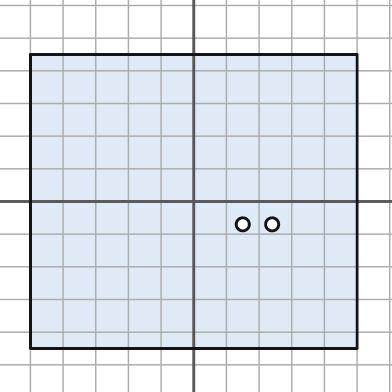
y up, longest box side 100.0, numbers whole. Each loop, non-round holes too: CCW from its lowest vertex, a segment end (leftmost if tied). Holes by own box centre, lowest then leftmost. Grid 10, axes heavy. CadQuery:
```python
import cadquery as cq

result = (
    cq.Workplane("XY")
    .moveTo(-50.0, -45.0)
    .lineTo(50.0, -45.0)
    .lineTo(50.0, 45.0)
    .lineTo(-50.0, 45.0)
    .close()
    .moveTo(15.0, -7.0)
    .circle(2.0)
    .moveTo(24.0, -7.0)
    .circle(2.0)
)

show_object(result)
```